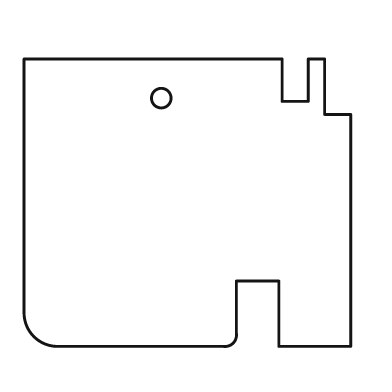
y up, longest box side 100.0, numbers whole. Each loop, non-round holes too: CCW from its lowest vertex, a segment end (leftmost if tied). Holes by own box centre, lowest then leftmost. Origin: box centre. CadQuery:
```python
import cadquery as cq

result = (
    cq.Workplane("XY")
    .moveTo(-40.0, -44.0)
    .lineTo(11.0, -44.0)
    .threePointArc((14.0, -43.0), (15.0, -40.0))
    .lineTo(15.0, -24.0)
    .lineTo(28.0, -24.0)
    .lineTo(28.0, -44.0)
    .lineTo(50.0, -44.0)
    .lineTo(50.0, 27.0)
    .lineTo(42.0, 27.0)
    .lineTo(42.0, 44.0)
    .lineTo(37.0, 44.0)
    .lineTo(37.0, 31.0)
    .lineTo(29.0, 31.0)
    .lineTo(29.0, 44.0)
    .lineTo(-50.0, 44.0)
    .lineTo(-50.0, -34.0)
    .threePointArc((-47.0, -41.0), (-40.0, -44.0))
    .close()
    .moveTo(-8.0, 32.0)
    .circle(3.0)
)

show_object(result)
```